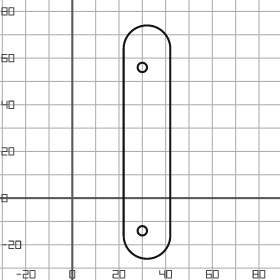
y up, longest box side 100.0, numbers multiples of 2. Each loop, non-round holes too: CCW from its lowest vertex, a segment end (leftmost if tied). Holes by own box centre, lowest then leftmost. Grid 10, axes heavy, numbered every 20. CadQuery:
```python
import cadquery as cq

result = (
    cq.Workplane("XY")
    .moveTo(22.0, -16.0)
    .threePointArc((32.0, -26.0), (42.0, -16.0))
    .lineTo(42.0, 64.0)
    .threePointArc((32.0, 74.0), (22.0, 64.0))
    .close()
    .moveTo(30.0, -14.0)
    .circle(2.0)
    .moveTo(30.0, 56.0)
    .circle(2.0)
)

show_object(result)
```